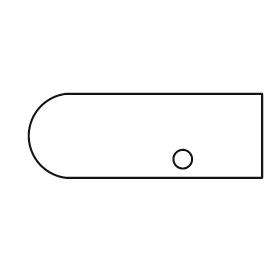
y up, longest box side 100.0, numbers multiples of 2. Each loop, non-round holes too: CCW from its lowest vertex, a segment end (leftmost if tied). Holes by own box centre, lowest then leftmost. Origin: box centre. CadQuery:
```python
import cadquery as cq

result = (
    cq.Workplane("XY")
    .moveTo(-34.0, -18.0)
    .lineTo(50.0, -18.0)
    .lineTo(50.0, 18.0)
    .lineTo(-34.0, 18.0)
    .threePointArc((-50.0, 0.0), (-34.0, -18.0))
    .close()
    .moveTo(16.0, -10.0)
    .circle(4.0)
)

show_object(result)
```